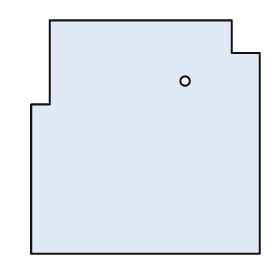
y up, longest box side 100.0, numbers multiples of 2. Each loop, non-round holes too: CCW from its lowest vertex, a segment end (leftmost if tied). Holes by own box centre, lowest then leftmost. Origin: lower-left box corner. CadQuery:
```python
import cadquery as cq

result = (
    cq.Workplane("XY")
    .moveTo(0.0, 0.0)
    .lineTo(98.0, 0.0)
    .lineTo(98.0, 86.0)
    .lineTo(86.0, 86.0)
    .lineTo(86.0, 100.0)
    .lineTo(8.0, 100.0)
    .lineTo(8.0, 64.0)
    .lineTo(0.0, 64.0)
    .close()
    .moveTo(66.0, 74.0)
    .circle(2.0)
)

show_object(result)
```